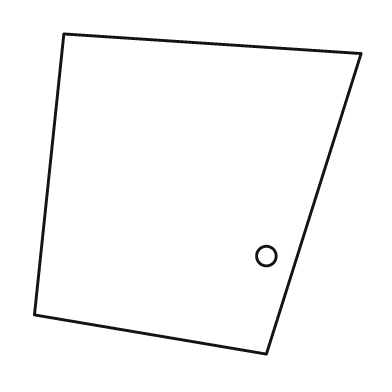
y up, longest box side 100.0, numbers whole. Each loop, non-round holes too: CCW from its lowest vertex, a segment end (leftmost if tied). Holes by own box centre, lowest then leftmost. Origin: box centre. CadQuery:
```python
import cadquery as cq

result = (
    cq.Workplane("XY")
    .moveTo(21.0, -49.0)
    .lineTo(50.0, 43.0)
    .lineTo(-41.0, 49.0)
    .lineTo(-50.0, -37.0)
    .close()
    .moveTo(21.0, -19.0)
    .circle(3.0)
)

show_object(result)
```